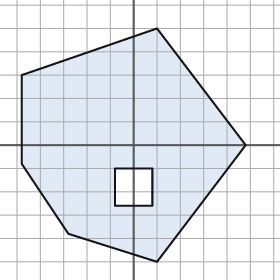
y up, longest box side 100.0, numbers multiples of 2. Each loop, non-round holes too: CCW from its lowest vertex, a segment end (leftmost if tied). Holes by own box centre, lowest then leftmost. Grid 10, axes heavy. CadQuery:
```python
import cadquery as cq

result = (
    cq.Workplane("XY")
    .moveTo(10.0, -50.0)
    .lineTo(48.0, 0.0)
    .lineTo(10.0, 50.0)
    .lineTo(-48.0, 30.0)
    .lineTo(-48.0, -8.0)
    .lineTo(-28.0, -38.0)
    .close()
    .moveTo(-8.0, -26.0)
    .lineTo(8.0, -26.0)
    .lineTo(8.0, -10.0)
    .lineTo(-8.0, -10.0)
    .close()
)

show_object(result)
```